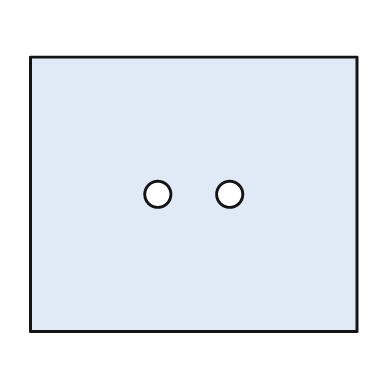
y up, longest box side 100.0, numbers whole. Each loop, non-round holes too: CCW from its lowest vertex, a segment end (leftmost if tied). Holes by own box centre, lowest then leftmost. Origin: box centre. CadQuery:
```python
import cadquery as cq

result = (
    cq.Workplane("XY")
    .moveTo(-50.0, -42.0)
    .lineTo(50.0, -42.0)
    .lineTo(50.0, 42.0)
    .lineTo(-50.0, 42.0)
    .close()
    .moveTo(-11.0, 0.0)
    .circle(4.0)
    .moveTo(11.0, 0.0)
    .circle(4.0)
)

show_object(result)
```